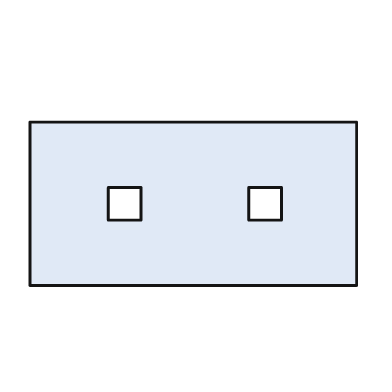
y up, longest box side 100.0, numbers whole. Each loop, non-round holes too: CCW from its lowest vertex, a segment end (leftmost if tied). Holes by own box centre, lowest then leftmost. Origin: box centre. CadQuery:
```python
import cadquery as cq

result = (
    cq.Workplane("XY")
    .moveTo(-50.0, -25.0)
    .lineTo(50.0, -25.0)
    .lineTo(50.0, 25.0)
    .lineTo(-50.0, 25.0)
    .close()
    .moveTo(-26.0, -5.0)
    .lineTo(-16.0, -5.0)
    .lineTo(-16.0, 5.0)
    .lineTo(-26.0, 5.0)
    .close()
    .moveTo(17.0, -5.0)
    .lineTo(27.0, -5.0)
    .lineTo(27.0, 5.0)
    .lineTo(17.0, 5.0)
    .close()
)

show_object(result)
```